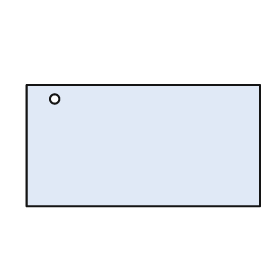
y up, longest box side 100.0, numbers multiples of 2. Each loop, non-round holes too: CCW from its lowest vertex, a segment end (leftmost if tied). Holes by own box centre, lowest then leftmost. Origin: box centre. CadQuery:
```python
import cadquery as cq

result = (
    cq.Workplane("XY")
    .moveTo(-50.0, -26.0)
    .lineTo(50.0, -26.0)
    .lineTo(50.0, 26.0)
    .lineTo(-50.0, 26.0)
    .close()
    .moveTo(-38.0, 20.0)
    .circle(2.0)
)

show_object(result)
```